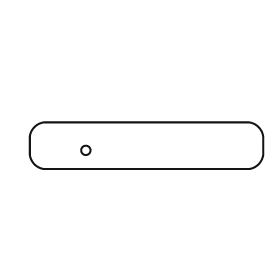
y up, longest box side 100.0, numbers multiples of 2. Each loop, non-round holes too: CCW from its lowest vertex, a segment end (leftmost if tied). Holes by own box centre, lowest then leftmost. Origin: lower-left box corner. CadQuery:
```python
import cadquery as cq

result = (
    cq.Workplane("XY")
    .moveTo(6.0, 0.0)
    .lineTo(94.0, 0.0)
    .threePointArc((98.0, 2.0), (100.0, 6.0))
    .lineTo(100.0, 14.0)
    .threePointArc((98.0, 18.0), (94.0, 20.0))
    .lineTo(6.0, 20.0)
    .threePointArc((2.0, 18.0), (0.0, 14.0))
    .lineTo(0.0, 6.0)
    .threePointArc((2.0, 2.0), (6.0, 0.0))
    .close()
    .moveTo(24.0, 8.0)
    .circle(2.0)
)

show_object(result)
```